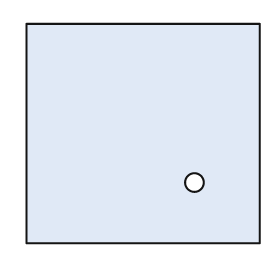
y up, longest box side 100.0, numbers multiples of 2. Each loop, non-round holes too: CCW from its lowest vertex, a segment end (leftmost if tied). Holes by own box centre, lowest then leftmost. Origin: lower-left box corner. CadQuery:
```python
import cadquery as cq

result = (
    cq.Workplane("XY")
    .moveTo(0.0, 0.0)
    .lineTo(100.0, 0.0)
    .lineTo(100.0, 94.0)
    .lineTo(0.0, 94.0)
    .close()
    .moveTo(72.0, 26.0)
    .circle(4.0)
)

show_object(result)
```